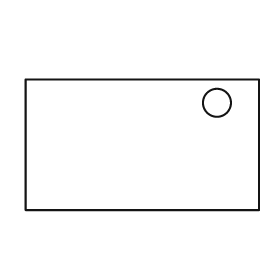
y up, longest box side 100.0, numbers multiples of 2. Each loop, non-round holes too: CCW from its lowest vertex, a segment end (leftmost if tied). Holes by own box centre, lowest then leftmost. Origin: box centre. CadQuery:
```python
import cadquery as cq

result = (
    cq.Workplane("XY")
    .moveTo(-50.0, -28.0)
    .lineTo(50.0, -28.0)
    .lineTo(50.0, 28.0)
    .lineTo(-50.0, 28.0)
    .close()
    .moveTo(32.0, 18.0)
    .circle(6.0)
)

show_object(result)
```